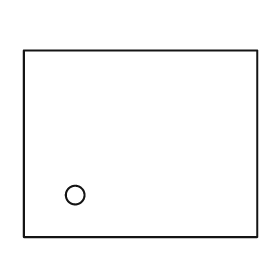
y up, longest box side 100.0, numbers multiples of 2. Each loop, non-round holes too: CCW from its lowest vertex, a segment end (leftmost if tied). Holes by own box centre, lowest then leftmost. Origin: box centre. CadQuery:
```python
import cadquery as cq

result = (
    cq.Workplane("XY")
    .moveTo(-50.0, -40.0)
    .lineTo(50.0, -40.0)
    .lineTo(50.0, 40.0)
    .lineTo(-50.0, 40.0)
    .close()
    .moveTo(-28.0, -22.0)
    .circle(4.0)
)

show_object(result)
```